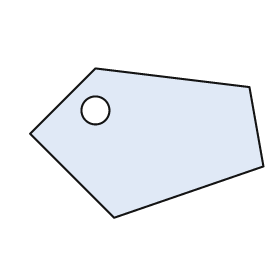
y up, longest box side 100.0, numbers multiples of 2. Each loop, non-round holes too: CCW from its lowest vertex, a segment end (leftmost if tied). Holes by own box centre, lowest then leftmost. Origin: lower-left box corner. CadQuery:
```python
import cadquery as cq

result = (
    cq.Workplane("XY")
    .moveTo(36.0, 0.0)
    .lineTo(100.0, 22.0)
    .lineTo(94.0, 56.0)
    .lineTo(28.0, 64.0)
    .lineTo(0.0, 36.0)
    .close()
    .moveTo(28.0, 46.0)
    .circle(6.0)
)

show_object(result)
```